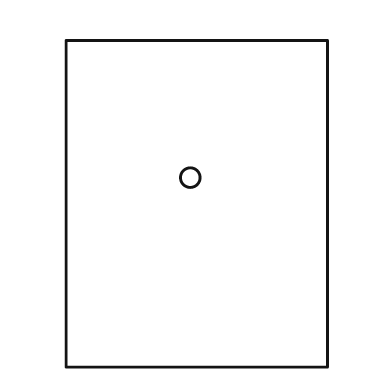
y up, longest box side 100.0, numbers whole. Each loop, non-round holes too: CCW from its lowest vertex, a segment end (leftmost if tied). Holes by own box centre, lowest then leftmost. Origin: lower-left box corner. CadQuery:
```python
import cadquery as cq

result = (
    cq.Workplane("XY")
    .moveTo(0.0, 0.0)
    .lineTo(80.0, 0.0)
    .lineTo(80.0, 100.0)
    .lineTo(0.0, 100.0)
    .close()
    .moveTo(38.0, 58.0)
    .circle(3.0)
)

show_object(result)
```